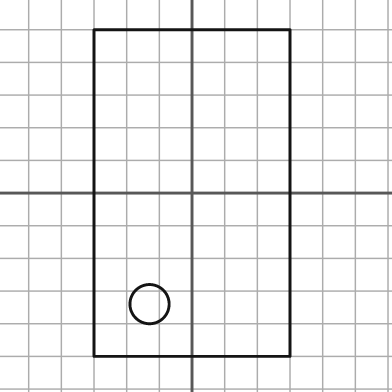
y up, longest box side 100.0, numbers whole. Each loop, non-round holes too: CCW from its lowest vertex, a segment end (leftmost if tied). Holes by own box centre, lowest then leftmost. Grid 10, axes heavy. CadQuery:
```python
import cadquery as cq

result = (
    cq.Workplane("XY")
    .moveTo(-30.0, -50.0)
    .lineTo(30.0, -50.0)
    .lineTo(30.0, 50.0)
    .lineTo(-30.0, 50.0)
    .close()
    .moveTo(-13.0, -34.0)
    .circle(6.0)
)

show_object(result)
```